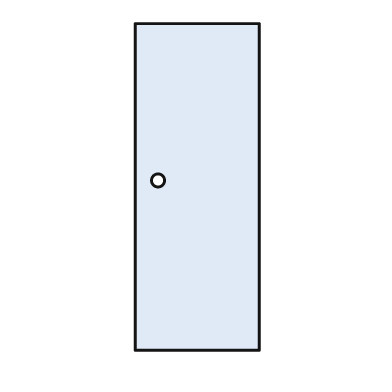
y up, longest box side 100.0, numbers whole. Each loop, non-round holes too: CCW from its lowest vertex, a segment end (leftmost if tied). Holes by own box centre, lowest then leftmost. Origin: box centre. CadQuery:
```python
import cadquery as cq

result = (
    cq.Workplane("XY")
    .moveTo(-19.0, -50.0)
    .lineTo(19.0, -50.0)
    .lineTo(19.0, 50.0)
    .lineTo(-19.0, 50.0)
    .close()
    .moveTo(-12.0, 2.0)
    .circle(2.0)
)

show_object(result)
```